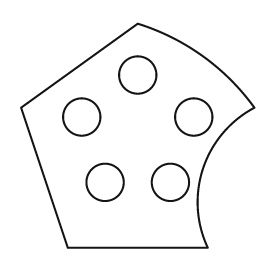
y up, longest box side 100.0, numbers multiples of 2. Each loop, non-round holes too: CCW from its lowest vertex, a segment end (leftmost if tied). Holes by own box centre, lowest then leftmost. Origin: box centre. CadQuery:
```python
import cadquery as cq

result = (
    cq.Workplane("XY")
    .moveTo(-30.0, -48.0)
    .lineTo(30.0, -48.0)
    .threePointArc((28.0, -14.0), (50.0, 12.0))
    .threePointArc((28.0, 34.0), (0.0, 48.0))
    .lineTo(-50.0, 12.0)
    .close()
    .moveTo(-14.0, -20.0)
    .circle(8.0)
    .moveTo(14.0, -20.0)
    .circle(8.0)
    .moveTo(-24.0, 8.0)
    .circle(8.0)
    .moveTo(24.0, 8.0)
    .circle(8.0)
    .moveTo(0.0, 26.0)
    .circle(8.0)
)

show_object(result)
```